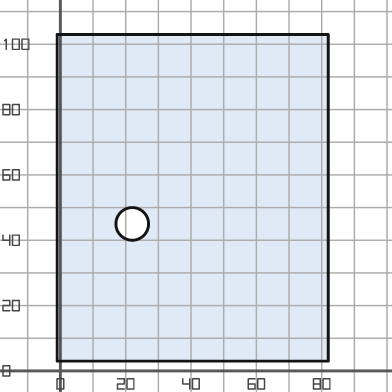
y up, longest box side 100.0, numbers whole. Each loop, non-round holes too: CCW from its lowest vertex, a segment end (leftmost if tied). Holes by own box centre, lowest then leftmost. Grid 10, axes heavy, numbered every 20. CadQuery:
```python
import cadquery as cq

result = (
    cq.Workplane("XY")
    .moveTo(-1.0, 3.0)
    .lineTo(82.0, 3.0)
    .lineTo(82.0, 103.0)
    .lineTo(-1.0, 103.0)
    .close()
    .moveTo(22.0, 45.0)
    .circle(5.0)
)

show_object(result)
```